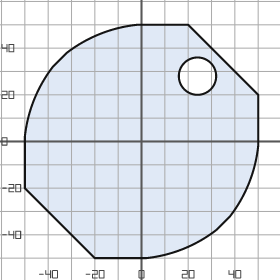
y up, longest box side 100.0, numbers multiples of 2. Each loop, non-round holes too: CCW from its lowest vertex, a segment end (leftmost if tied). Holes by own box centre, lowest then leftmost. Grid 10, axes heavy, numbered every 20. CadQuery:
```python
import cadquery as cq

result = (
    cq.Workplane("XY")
    .moveTo(-20.0, -50.0)
    .lineTo(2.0, -50.0)
    .threePointArc((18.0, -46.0), (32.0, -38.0))
    .lineTo(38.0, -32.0)
    .threePointArc((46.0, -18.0), (50.0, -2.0))
    .lineTo(50.0, 20.0)
    .lineTo(20.0, 50.0)
    .lineTo(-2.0, 50.0)
    .threePointArc((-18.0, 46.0), (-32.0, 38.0))
    .lineTo(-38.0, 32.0)
    .threePointArc((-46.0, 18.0), (-50.0, 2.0))
    .lineTo(-50.0, -20.0)
    .close()
    .moveTo(24.0, 28.0)
    .circle(8.0)
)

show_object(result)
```